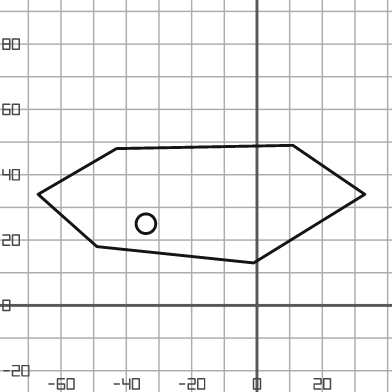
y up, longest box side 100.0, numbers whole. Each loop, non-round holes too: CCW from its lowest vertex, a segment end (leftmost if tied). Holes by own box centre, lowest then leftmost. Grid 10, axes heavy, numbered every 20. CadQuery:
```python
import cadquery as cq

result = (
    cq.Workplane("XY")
    .moveTo(-1.0, 13.0)
    .lineTo(33.0, 34.0)
    .lineTo(11.0, 49.0)
    .lineTo(-43.0, 48.0)
    .lineTo(-67.0, 34.0)
    .lineTo(-49.0, 18.0)
    .close()
    .moveTo(-34.0, 25.0)
    .circle(3.0)
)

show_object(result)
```